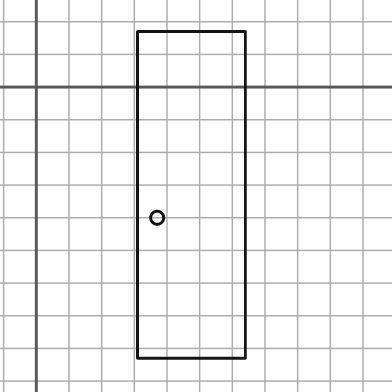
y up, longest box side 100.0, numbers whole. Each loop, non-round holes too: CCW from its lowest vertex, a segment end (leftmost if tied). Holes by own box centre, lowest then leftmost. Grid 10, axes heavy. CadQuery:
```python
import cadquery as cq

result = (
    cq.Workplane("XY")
    .moveTo(31.0, -83.0)
    .lineTo(64.0, -83.0)
    .lineTo(64.0, 17.0)
    .lineTo(31.0, 17.0)
    .close()
    .moveTo(37.0, -40.0)
    .circle(2.0)
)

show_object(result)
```